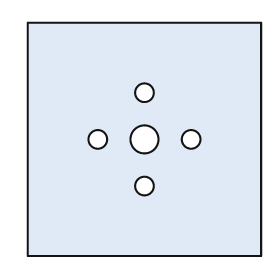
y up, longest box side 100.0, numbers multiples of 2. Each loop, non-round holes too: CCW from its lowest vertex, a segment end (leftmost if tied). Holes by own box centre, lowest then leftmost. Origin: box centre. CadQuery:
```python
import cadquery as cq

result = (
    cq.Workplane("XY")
    .moveTo(-50.0, -50.0)
    .lineTo(50.0, -50.0)
    .lineTo(50.0, 50.0)
    .lineTo(-50.0, 50.0)
    .close()
    .moveTo(0.0, -20.0)
    .circle(4.0)
    .moveTo(-20.0, 0.0)
    .circle(4.0)
    .moveTo(0.0, 0.0)
    .circle(6.0)
    .moveTo(20.0, 0.0)
    .circle(4.0)
    .moveTo(0.0, 20.0)
    .circle(4.0)
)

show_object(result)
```